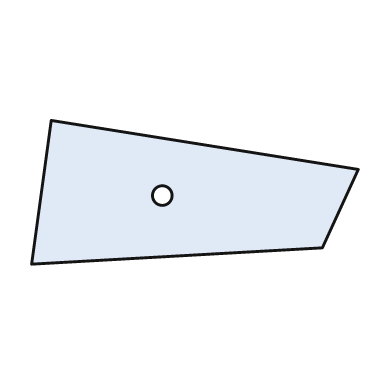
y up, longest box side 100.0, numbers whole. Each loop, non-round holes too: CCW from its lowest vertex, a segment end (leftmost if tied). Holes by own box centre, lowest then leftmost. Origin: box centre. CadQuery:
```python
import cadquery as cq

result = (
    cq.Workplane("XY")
    .moveTo(-50.0, -22.0)
    .lineTo(39.0, -17.0)
    .lineTo(50.0, 7.0)
    .lineTo(-44.0, 22.0)
    .close()
    .moveTo(-10.0, -1.0)
    .circle(3.0)
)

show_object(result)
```